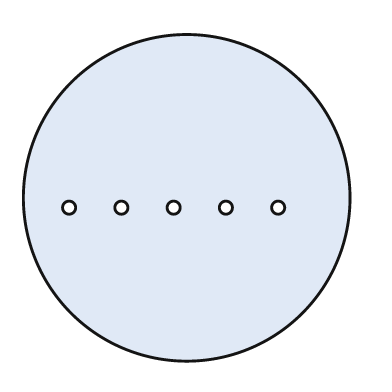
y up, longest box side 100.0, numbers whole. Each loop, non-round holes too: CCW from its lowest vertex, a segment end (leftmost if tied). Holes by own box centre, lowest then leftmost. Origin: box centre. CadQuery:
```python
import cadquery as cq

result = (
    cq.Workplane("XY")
    .moveTo(0.0, 0.0)
    .circle(50.0)
    .moveTo(-36.0, -3.0)
    .circle(2.0)
    .moveTo(-20.0, -3.0)
    .circle(2.0)
    .moveTo(-4.0, -3.0)
    .circle(2.0)
    .moveTo(12.0, -3.0)
    .circle(2.0)
    .moveTo(28.0, -3.0)
    .circle(2.0)
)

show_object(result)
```